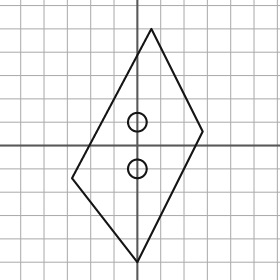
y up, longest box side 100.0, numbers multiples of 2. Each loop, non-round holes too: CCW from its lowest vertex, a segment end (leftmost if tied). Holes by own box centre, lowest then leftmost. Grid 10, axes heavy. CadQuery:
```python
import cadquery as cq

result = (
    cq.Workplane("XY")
    .moveTo(0.0, -50.0)
    .lineTo(28.0, 6.0)
    .lineTo(6.0, 50.0)
    .lineTo(-28.0, -14.0)
    .close()
    .moveTo(0.0, -10.0)
    .circle(4.0)
    .moveTo(0.0, 10.0)
    .circle(4.0)
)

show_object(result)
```